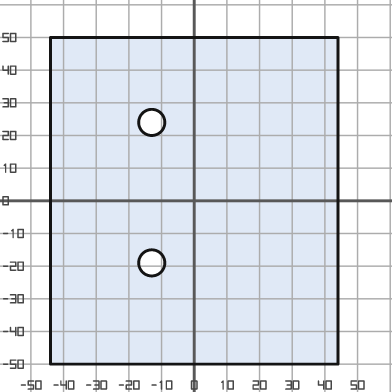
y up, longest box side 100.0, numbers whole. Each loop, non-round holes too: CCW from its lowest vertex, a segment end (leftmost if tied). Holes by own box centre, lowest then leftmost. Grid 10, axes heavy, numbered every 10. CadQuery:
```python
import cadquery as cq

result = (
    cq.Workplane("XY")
    .moveTo(-44.0, -50.0)
    .lineTo(44.0, -50.0)
    .lineTo(44.0, 50.0)
    .lineTo(-44.0, 50.0)
    .close()
    .moveTo(-13.0, -19.0)
    .circle(4.0)
    .moveTo(-13.0, 24.0)
    .circle(4.0)
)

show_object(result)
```